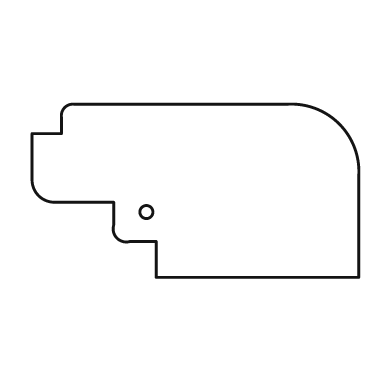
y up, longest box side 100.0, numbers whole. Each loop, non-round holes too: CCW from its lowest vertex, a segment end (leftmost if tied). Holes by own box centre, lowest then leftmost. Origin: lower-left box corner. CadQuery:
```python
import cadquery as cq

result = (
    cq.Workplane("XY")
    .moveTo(38.0, 0.0)
    .lineTo(100.0, 0.0)
    .lineTo(100.0, 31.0)
    .threePointArc((94.0, 47.0), (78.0, 53.0))
    .lineTo(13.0, 53.0)
    .threePointArc((10.0, 52.0), (9.0, 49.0))
    .lineTo(9.0, 44.0)
    .lineTo(0.0, 44.0)
    .lineTo(0.0, 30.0)
    .threePointArc((2.0, 25.0), (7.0, 23.0))
    .lineTo(25.0, 23.0)
    .lineTo(25.0, 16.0)
    .threePointArc((26.0, 12.0), (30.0, 11.0))
    .lineTo(38.0, 11.0)
    .close()
    .moveTo(35.0, 20.0)
    .circle(2.0)
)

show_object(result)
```